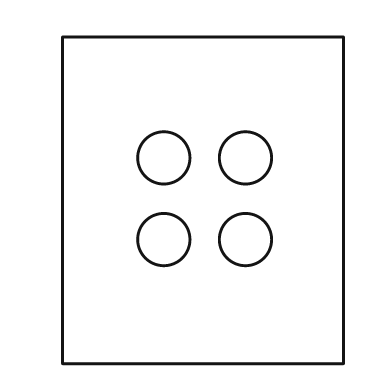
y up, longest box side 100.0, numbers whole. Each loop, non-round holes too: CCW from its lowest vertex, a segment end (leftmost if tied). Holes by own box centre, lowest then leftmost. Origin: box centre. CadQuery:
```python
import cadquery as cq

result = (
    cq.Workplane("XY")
    .moveTo(-43.0, -50.0)
    .lineTo(43.0, -50.0)
    .lineTo(43.0, 50.0)
    .lineTo(-43.0, 50.0)
    .close()
    .moveTo(-12.0, -12.0)
    .circle(8.0)
    .moveTo(13.0, -12.0)
    .circle(8.0)
    .moveTo(-12.0, 13.0)
    .circle(8.0)
    .moveTo(13.0, 13.0)
    .circle(8.0)
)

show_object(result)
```